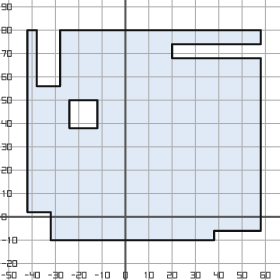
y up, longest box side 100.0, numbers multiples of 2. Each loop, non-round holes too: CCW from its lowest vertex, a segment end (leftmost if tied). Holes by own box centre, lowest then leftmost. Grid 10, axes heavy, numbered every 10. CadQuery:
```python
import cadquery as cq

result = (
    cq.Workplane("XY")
    .moveTo(-32.0, -10.0)
    .lineTo(38.0, -10.0)
    .lineTo(38.0, -6.0)
    .lineTo(58.0, -6.0)
    .lineTo(58.0, 68.0)
    .lineTo(20.0, 68.0)
    .lineTo(20.0, 74.0)
    .lineTo(58.0, 74.0)
    .lineTo(58.0, 80.0)
    .lineTo(-28.0, 80.0)
    .lineTo(-28.0, 56.0)
    .lineTo(-38.0, 56.0)
    .lineTo(-38.0, 80.0)
    .lineTo(-42.0, 80.0)
    .lineTo(-42.0, 2.0)
    .lineTo(-32.0, 2.0)
    .close()
    .moveTo(-24.0, 38.0)
    .lineTo(-12.0, 38.0)
    .lineTo(-12.0, 50.0)
    .lineTo(-24.0, 50.0)
    .close()
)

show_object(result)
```